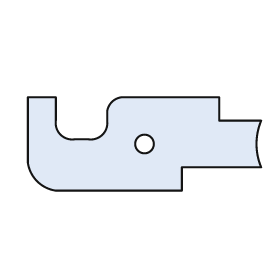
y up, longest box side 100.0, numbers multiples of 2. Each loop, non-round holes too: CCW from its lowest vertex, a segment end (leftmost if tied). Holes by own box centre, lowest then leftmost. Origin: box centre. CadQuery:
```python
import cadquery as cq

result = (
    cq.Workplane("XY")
    .moveTo(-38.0, -20.0)
    .lineTo(16.0, -20.0)
    .lineTo(16.0, -10.0)
    .lineTo(50.0, -10.0)
    .threePointArc((48.0, 0.0), (50.0, 10.0))
    .lineTo(32.0, 10.0)
    .lineTo(32.0, 20.0)
    .lineTo(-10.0, 20.0)
    .threePointArc((-14.0, 18.0), (-16.0, 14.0))
    .lineTo(-16.0, 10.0)
    .threePointArc((-18.0, 4.0), (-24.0, 2.0))
    .lineTo(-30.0, 2.0)
    .threePointArc((-36.0, 4.0), (-38.0, 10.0))
    .lineTo(-38.0, 20.0)
    .lineTo(-50.0, 20.0)
    .lineTo(-50.0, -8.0)
    .threePointArc((-46.0, -16.0), (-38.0, -20.0))
    .close()
    .moveTo(0.0, 0.0)
    .circle(4.0)
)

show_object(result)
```